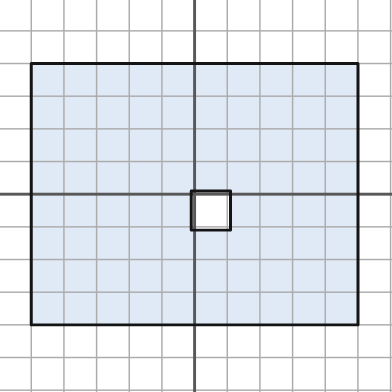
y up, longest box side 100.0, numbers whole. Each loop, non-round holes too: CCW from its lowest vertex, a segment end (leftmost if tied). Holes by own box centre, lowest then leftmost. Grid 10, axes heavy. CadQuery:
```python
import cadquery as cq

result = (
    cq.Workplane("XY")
    .moveTo(-50.0, -40.0)
    .lineTo(50.0, -40.0)
    .lineTo(50.0, 40.0)
    .lineTo(-50.0, 40.0)
    .close()
    .moveTo(-1.0, -11.0)
    .lineTo(11.0, -11.0)
    .lineTo(11.0, 1.0)
    .lineTo(-1.0, 1.0)
    .close()
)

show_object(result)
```